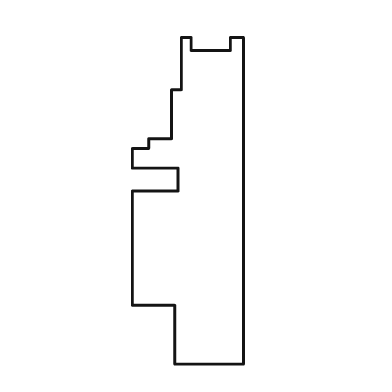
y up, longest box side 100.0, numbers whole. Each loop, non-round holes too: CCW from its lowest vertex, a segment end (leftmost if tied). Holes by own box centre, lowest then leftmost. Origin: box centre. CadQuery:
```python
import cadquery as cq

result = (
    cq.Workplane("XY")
    .moveTo(-4.0, -50.0)
    .lineTo(17.0, -50.0)
    .lineTo(17.0, 50.0)
    .lineTo(13.0, 50.0)
    .lineTo(13.0, 46.0)
    .lineTo(1.0, 46.0)
    .lineTo(1.0, 50.0)
    .lineTo(-2.0, 50.0)
    .lineTo(-2.0, 34.0)
    .lineTo(-5.0, 34.0)
    .lineTo(-5.0, 19.0)
    .lineTo(-12.0, 19.0)
    .lineTo(-12.0, 16.0)
    .lineTo(-17.0, 16.0)
    .lineTo(-17.0, 10.0)
    .lineTo(-3.0, 10.0)
    .lineTo(-3.0, 3.0)
    .lineTo(-17.0, 3.0)
    .lineTo(-17.0, -32.0)
    .lineTo(-4.0, -32.0)
    .close()
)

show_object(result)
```